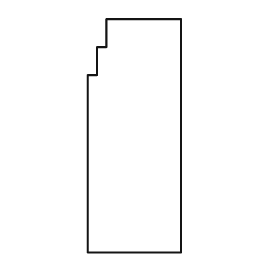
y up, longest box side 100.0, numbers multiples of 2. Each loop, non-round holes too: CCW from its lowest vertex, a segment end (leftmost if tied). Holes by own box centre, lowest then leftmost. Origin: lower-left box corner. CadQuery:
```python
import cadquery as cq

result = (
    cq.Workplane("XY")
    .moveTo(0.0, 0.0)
    .lineTo(40.0, 0.0)
    .lineTo(40.0, 100.0)
    .lineTo(8.0, 100.0)
    .lineTo(8.0, 88.0)
    .lineTo(4.0, 88.0)
    .lineTo(4.0, 76.0)
    .lineTo(0.0, 76.0)
    .close()
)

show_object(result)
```